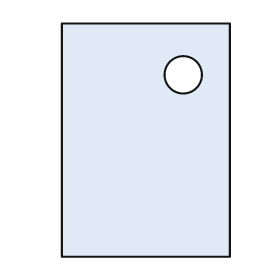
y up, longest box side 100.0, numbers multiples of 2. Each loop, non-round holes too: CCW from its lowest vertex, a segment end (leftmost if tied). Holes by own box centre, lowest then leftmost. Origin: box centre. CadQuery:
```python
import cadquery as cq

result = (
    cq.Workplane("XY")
    .moveTo(-36.0, -50.0)
    .lineTo(36.0, -50.0)
    .lineTo(36.0, 50.0)
    .lineTo(-36.0, 50.0)
    .close()
    .moveTo(16.0, 28.0)
    .circle(8.0)
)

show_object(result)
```